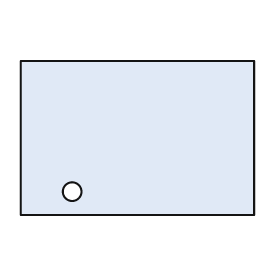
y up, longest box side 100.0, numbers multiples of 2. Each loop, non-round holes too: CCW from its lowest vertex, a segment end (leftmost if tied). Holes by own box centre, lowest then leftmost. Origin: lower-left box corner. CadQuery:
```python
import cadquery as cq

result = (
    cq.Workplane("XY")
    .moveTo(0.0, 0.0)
    .lineTo(100.0, 0.0)
    .lineTo(100.0, 66.0)
    .lineTo(0.0, 66.0)
    .close()
    .moveTo(22.0, 10.0)
    .circle(4.0)
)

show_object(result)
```